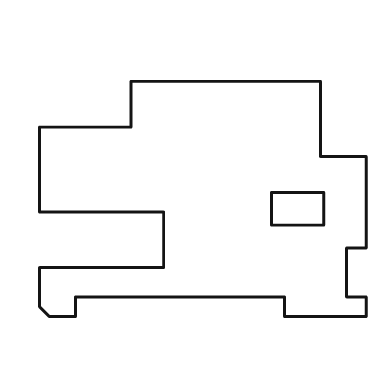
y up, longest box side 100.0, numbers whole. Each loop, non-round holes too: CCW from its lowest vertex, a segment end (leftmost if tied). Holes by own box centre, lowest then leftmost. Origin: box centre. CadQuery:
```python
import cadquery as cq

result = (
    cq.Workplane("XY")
    .moveTo(-47.0, -36.0)
    .lineTo(-39.0, -36.0)
    .lineTo(-39.0, -30.0)
    .lineTo(25.0, -30.0)
    .lineTo(25.0, -36.0)
    .lineTo(50.0, -36.0)
    .lineTo(50.0, -30.0)
    .lineTo(44.0, -30.0)
    .lineTo(44.0, -15.0)
    .lineTo(50.0, -15.0)
    .lineTo(50.0, 13.0)
    .lineTo(36.0, 13.0)
    .lineTo(36.0, 36.0)
    .lineTo(-22.0, 36.0)
    .lineTo(-22.0, 22.0)
    .lineTo(-50.0, 22.0)
    .lineTo(-50.0, -4.0)
    .lineTo(-12.0, -4.0)
    .lineTo(-12.0, -21.0)
    .lineTo(-50.0, -21.0)
    .lineTo(-50.0, -33.0)
    .close()
    .moveTo(21.0, -8.0)
    .lineTo(37.0, -8.0)
    .lineTo(37.0, 2.0)
    .lineTo(21.0, 2.0)
    .close()
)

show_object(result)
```